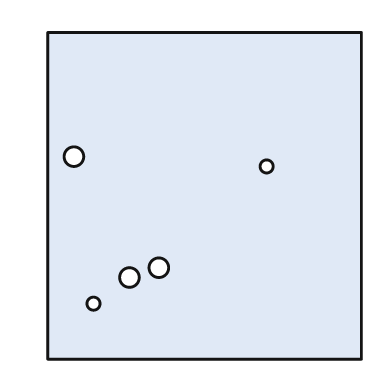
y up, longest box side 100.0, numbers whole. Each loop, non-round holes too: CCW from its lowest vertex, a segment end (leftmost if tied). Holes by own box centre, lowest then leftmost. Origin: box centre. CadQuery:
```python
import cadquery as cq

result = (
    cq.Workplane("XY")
    .moveTo(-48.0, -50.0)
    .lineTo(48.0, -50.0)
    .lineTo(48.0, 50.0)
    .lineTo(-48.0, 50.0)
    .close()
    .moveTo(-34.0, -33.0)
    .circle(2.0)
    .moveTo(-23.0, -25.0)
    .circle(3.0)
    .moveTo(-14.0, -22.0)
    .circle(3.0)
    .moveTo(19.0, 9.0)
    .circle(2.0)
    .moveTo(-40.0, 12.0)
    .circle(3.0)
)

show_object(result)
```